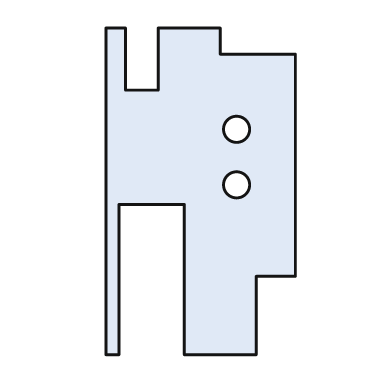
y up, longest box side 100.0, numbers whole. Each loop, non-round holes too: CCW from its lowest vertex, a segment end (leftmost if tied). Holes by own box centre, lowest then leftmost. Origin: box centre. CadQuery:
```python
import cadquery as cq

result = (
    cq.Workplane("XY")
    .moveTo(-29.0, -50.0)
    .lineTo(-25.0, -50.0)
    .lineTo(-25.0, -4.0)
    .lineTo(-5.0, -4.0)
    .lineTo(-5.0, -50.0)
    .lineTo(17.0, -50.0)
    .lineTo(17.0, -26.0)
    .lineTo(29.0, -26.0)
    .lineTo(29.0, 42.0)
    .lineTo(6.0, 42.0)
    .lineTo(6.0, 50.0)
    .lineTo(-13.0, 50.0)
    .lineTo(-13.0, 31.0)
    .lineTo(-23.0, 31.0)
    .lineTo(-23.0, 50.0)
    .lineTo(-29.0, 50.0)
    .close()
    .moveTo(11.0, 2.0)
    .circle(4.0)
    .moveTo(11.0, 19.0)
    .circle(4.0)
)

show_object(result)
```